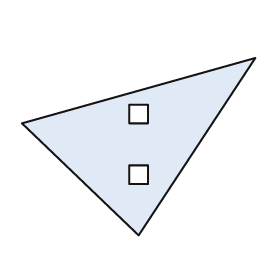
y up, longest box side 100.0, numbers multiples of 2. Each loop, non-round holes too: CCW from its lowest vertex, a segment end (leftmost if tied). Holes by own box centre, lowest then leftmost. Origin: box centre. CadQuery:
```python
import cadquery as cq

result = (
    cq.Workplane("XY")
    .moveTo(0.0, -38.0)
    .lineTo(50.0, 38.0)
    .lineTo(-50.0, 10.0)
    .close()
    .moveTo(-4.0, -16.0)
    .lineTo(4.0, -16.0)
    .lineTo(4.0, -8.0)
    .lineTo(-4.0, -8.0)
    .close()
    .moveTo(-4.0, 10.0)
    .lineTo(4.0, 10.0)
    .lineTo(4.0, 18.0)
    .lineTo(-4.0, 18.0)
    .close()
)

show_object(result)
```